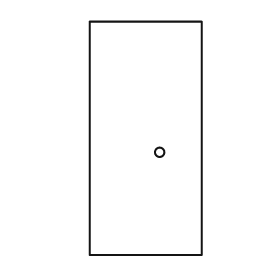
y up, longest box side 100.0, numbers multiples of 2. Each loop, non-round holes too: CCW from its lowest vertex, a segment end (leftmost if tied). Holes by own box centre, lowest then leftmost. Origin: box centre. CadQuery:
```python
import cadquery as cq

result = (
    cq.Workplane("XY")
    .moveTo(-24.0, -50.0)
    .lineTo(24.0, -50.0)
    .lineTo(24.0, 50.0)
    .lineTo(-24.0, 50.0)
    .close()
    .moveTo(6.0, -6.0)
    .circle(2.0)
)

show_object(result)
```